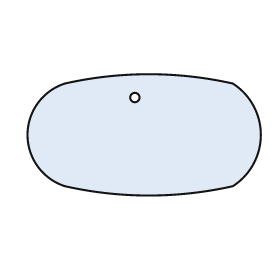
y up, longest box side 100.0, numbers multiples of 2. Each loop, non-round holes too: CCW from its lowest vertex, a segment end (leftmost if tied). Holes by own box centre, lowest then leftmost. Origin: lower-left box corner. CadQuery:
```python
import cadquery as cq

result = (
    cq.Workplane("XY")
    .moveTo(16.0, 4.0)
    .threePointArc((52.0, 0.0), (88.0, 4.0))
    .threePointArc((100.0, 26.0), (88.0, 48.0))
    .threePointArc((52.0, 52.0), (16.0, 48.0))
    .threePointArc((0.0, 26.0), (16.0, 4.0))
    .close()
    .moveTo(46.0, 42.0)
    .circle(2.0)
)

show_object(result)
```